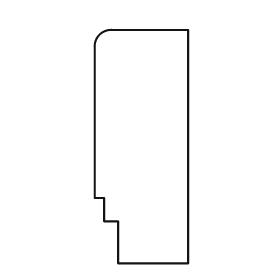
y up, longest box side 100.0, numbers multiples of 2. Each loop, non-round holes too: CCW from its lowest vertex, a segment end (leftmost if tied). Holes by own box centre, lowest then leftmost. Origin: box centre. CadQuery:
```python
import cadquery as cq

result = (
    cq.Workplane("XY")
    .moveTo(-10.0, -50.0)
    .lineTo(20.0, -50.0)
    .lineTo(20.0, 50.0)
    .lineTo(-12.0, 50.0)
    .threePointArc((-18.0, 48.0), (-20.0, 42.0))
    .lineTo(-20.0, -22.0)
    .lineTo(-16.0, -22.0)
    .lineTo(-16.0, -32.0)
    .lineTo(-10.0, -32.0)
    .close()
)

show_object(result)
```